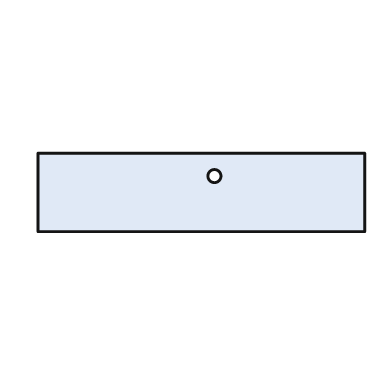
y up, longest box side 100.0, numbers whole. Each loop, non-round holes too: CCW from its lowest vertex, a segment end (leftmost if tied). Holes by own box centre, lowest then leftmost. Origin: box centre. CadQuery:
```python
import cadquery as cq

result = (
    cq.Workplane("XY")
    .moveTo(-50.0, -12.0)
    .lineTo(50.0, -12.0)
    .lineTo(50.0, 12.0)
    .lineTo(-50.0, 12.0)
    .close()
    .moveTo(4.0, 5.0)
    .circle(2.0)
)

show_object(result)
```